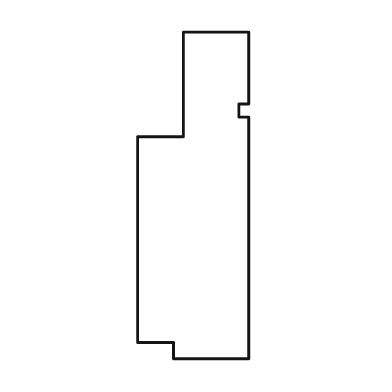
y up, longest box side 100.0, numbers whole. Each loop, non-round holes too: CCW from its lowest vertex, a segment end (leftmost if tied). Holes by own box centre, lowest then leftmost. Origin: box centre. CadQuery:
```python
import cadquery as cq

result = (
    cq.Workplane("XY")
    .moveTo(-6.0, -50.0)
    .lineTo(17.0, -50.0)
    .lineTo(17.0, 24.0)
    .lineTo(14.0, 24.0)
    .lineTo(14.0, 28.0)
    .lineTo(17.0, 28.0)
    .lineTo(17.0, 50.0)
    .lineTo(-3.0, 50.0)
    .lineTo(-3.0, 18.0)
    .lineTo(-17.0, 18.0)
    .lineTo(-17.0, -45.0)
    .lineTo(-6.0, -45.0)
    .close()
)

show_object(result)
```